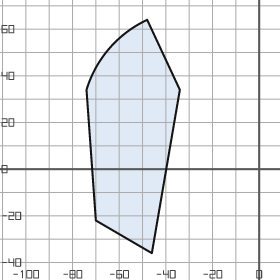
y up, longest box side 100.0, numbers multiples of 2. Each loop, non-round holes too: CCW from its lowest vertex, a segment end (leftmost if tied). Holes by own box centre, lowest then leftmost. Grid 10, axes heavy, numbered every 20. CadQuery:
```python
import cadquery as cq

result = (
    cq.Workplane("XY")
    .moveTo(-46.0, -36.0)
    .lineTo(-34.0, 34.0)
    .lineTo(-48.0, 64.0)
    .threePointArc((-64.0, 52.0), (-74.0, 34.0))
    .lineTo(-70.0, -22.0)
    .close()
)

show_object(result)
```